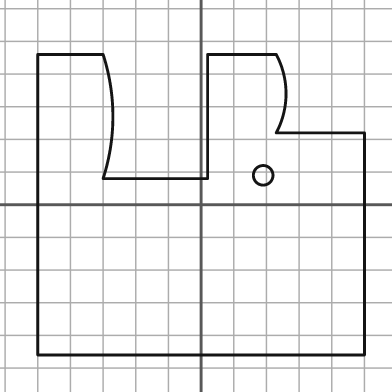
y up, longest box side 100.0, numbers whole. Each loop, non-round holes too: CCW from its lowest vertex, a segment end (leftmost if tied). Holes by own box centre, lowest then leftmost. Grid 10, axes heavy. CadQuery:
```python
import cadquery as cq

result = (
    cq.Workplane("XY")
    .moveTo(-50.0, -46.0)
    .lineTo(50.0, -46.0)
    .lineTo(50.0, 22.0)
    .lineTo(23.0, 22.0)
    .threePointArc((26.0, 34.0), (23.0, 46.0))
    .lineTo(2.0, 46.0)
    .lineTo(2.0, 8.0)
    .lineTo(-30.0, 8.0)
    .threePointArc((-27.0, 27.0), (-30.0, 46.0))
    .lineTo(-50.0, 46.0)
    .close()
    .moveTo(19.0, 9.0)
    .circle(3.0)
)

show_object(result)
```